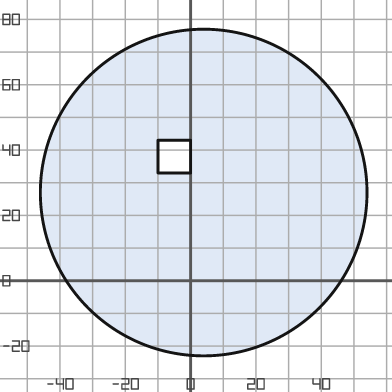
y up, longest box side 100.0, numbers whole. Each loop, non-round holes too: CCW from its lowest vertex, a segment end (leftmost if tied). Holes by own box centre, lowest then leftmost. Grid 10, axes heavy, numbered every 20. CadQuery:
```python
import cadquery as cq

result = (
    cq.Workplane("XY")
    .moveTo(4.0, 27.0)
    .circle(50.0)
    .moveTo(-10.0, 33.0)
    .lineTo(0.0, 33.0)
    .lineTo(0.0, 43.0)
    .lineTo(-10.0, 43.0)
    .close()
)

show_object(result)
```